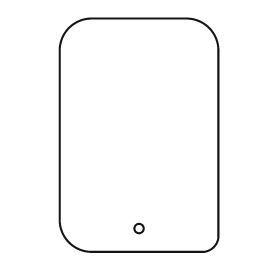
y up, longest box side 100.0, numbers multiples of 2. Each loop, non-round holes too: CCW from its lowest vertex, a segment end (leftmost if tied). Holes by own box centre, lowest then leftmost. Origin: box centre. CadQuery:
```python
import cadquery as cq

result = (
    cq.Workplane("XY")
    .moveTo(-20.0, -50.0)
    .lineTo(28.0, -50.0)
    .threePointArc((32.0, -48.0), (34.0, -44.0))
    .lineTo(34.0, 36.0)
    .threePointArc((30.0, 46.0), (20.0, 50.0))
    .lineTo(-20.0, 50.0)
    .threePointArc((-30.0, 46.0), (-34.0, 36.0))
    .lineTo(-34.0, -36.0)
    .threePointArc((-30.0, -46.0), (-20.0, -50.0))
    .close()
    .moveTo(0.0, -40.0)
    .circle(2.0)
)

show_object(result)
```